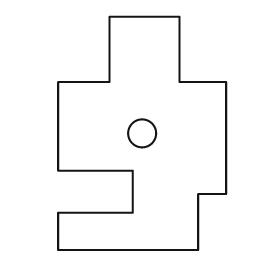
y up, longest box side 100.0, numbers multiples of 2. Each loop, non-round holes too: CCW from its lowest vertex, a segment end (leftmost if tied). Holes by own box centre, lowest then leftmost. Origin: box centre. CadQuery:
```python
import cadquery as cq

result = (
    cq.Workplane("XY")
    .moveTo(-36.0, -50.0)
    .lineTo(24.0, -50.0)
    .lineTo(24.0, -26.0)
    .lineTo(36.0, -26.0)
    .lineTo(36.0, 22.0)
    .lineTo(16.0, 22.0)
    .lineTo(16.0, 50.0)
    .lineTo(-14.0, 50.0)
    .lineTo(-14.0, 22.0)
    .lineTo(-36.0, 22.0)
    .lineTo(-36.0, -16.0)
    .lineTo(-4.0, -16.0)
    .lineTo(-4.0, -34.0)
    .lineTo(-36.0, -34.0)
    .close()
    .moveTo(0.0, 0.0)
    .circle(6.0)
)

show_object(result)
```